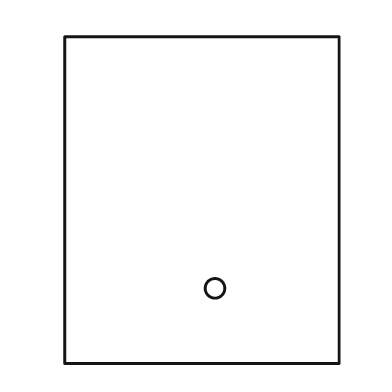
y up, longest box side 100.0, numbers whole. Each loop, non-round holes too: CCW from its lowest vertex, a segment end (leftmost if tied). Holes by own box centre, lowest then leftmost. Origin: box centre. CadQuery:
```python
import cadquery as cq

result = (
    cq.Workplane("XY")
    .moveTo(-42.0, -50.0)
    .lineTo(42.0, -50.0)
    .lineTo(42.0, 50.0)
    .lineTo(-42.0, 50.0)
    .close()
    .moveTo(4.0, -27.0)
    .circle(3.0)
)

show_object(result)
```